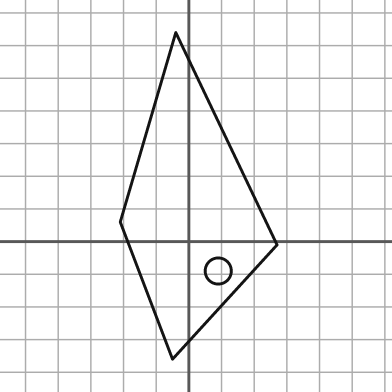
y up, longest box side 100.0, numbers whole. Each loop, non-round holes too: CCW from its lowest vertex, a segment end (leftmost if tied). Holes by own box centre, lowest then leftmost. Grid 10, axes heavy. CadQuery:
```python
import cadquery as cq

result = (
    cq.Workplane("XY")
    .moveTo(-5.0, -36.0)
    .lineTo(27.0, -1.0)
    .lineTo(-4.0, 64.0)
    .lineTo(-21.0, 6.0)
    .close()
    .moveTo(9.0, -9.0)
    .circle(4.0)
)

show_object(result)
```